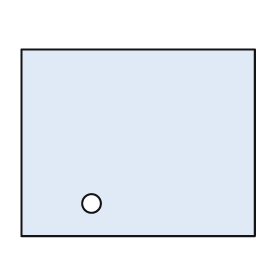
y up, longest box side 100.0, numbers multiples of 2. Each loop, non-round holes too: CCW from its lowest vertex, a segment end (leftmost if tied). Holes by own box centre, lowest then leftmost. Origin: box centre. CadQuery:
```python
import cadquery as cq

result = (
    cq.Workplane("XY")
    .moveTo(-50.0, -40.0)
    .lineTo(50.0, -40.0)
    .lineTo(50.0, 40.0)
    .lineTo(-50.0, 40.0)
    .close()
    .moveTo(-20.0, -26.0)
    .circle(4.0)
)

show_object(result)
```